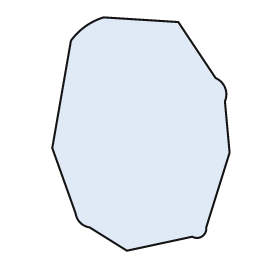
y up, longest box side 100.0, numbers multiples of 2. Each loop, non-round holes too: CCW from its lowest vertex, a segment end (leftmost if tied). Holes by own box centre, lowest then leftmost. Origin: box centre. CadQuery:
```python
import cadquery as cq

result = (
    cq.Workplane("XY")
    .moveTo(-6.0, -50.0)
    .lineTo(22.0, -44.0)
    .threePointArc((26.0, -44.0), (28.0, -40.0))
    .lineTo(38.0, -8.0)
    .lineTo(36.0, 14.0)
    .threePointArc((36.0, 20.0), (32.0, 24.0))
    .lineTo(16.0, 48.0)
    .lineTo(-16.0, 50.0)
    .threePointArc((-24.0, 46.0), (-30.0, 40.0))
    .lineTo(-38.0, -6.0)
    .lineTo(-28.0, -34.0)
    .threePointArc((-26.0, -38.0), (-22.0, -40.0))
    .close()
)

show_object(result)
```